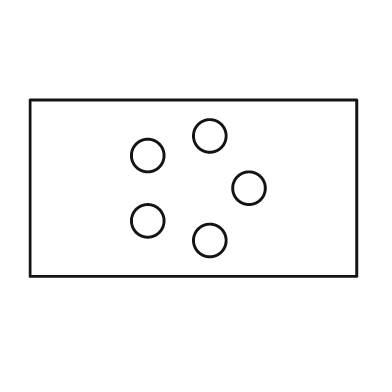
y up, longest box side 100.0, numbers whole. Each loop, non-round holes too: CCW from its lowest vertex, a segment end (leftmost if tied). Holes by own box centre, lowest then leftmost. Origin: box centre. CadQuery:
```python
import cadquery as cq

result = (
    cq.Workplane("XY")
    .moveTo(-50.0, -27.0)
    .lineTo(50.0, -27.0)
    .lineTo(50.0, 27.0)
    .lineTo(-50.0, 27.0)
    .close()
    .moveTo(5.0, -16.0)
    .circle(5.0)
    .moveTo(-14.0, -10.0)
    .circle(5.0)
    .moveTo(17.0, 0.0)
    .circle(5.0)
    .moveTo(-14.0, 10.0)
    .circle(5.0)
    .moveTo(5.0, 16.0)
    .circle(5.0)
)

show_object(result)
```